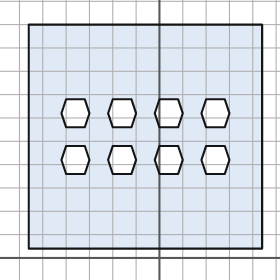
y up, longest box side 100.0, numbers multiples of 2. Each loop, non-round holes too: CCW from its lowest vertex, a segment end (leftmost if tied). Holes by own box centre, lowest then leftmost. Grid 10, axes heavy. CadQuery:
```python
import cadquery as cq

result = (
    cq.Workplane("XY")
    .moveTo(-56.0, 4.0)
    .lineTo(44.0, 4.0)
    .lineTo(44.0, 100.0)
    .lineTo(-56.0, 100.0)
    .close()
    .moveTo(-40.0, 36.0)
    .lineTo(-32.0, 36.0)
    .lineTo(-30.0, 42.0)
    .lineTo(-32.0, 48.0)
    .lineTo(-40.0, 48.0)
    .lineTo(-42.0, 42.0)
    .close()
    .moveTo(-20.0, 36.0)
    .lineTo(-12.0, 36.0)
    .lineTo(-10.0, 42.0)
    .lineTo(-12.0, 48.0)
    .lineTo(-20.0, 48.0)
    .lineTo(-22.0, 42.0)
    .close()
    .moveTo(0.0, 36.0)
    .lineTo(8.0, 36.0)
    .lineTo(10.0, 42.0)
    .lineTo(8.0, 48.0)
    .lineTo(0.0, 48.0)
    .lineTo(-2.0, 42.0)
    .close()
    .moveTo(20.0, 36.0)
    .lineTo(28.0, 36.0)
    .lineTo(30.0, 42.0)
    .lineTo(28.0, 48.0)
    .lineTo(20.0, 48.0)
    .lineTo(18.0, 42.0)
    .close()
    .moveTo(-40.0, 56.0)
    .lineTo(-32.0, 56.0)
    .lineTo(-30.0, 62.0)
    .lineTo(-32.0, 68.0)
    .lineTo(-40.0, 68.0)
    .lineTo(-42.0, 62.0)
    .close()
    .moveTo(-20.0, 56.0)
    .lineTo(-12.0, 56.0)
    .lineTo(-10.0, 62.0)
    .lineTo(-12.0, 68.0)
    .lineTo(-20.0, 68.0)
    .lineTo(-22.0, 62.0)
    .close()
    .moveTo(0.0, 56.0)
    .lineTo(8.0, 56.0)
    .lineTo(10.0, 62.0)
    .lineTo(8.0, 68.0)
    .lineTo(0.0, 68.0)
    .lineTo(-2.0, 62.0)
    .close()
    .moveTo(20.0, 56.0)
    .lineTo(28.0, 56.0)
    .lineTo(30.0, 62.0)
    .lineTo(28.0, 68.0)
    .lineTo(20.0, 68.0)
    .lineTo(18.0, 62.0)
    .close()
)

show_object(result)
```